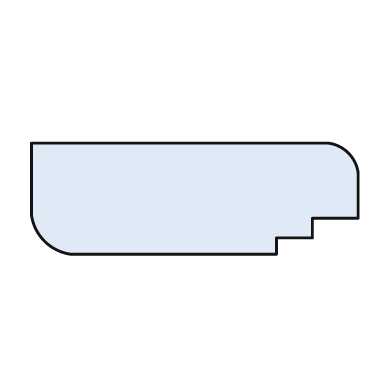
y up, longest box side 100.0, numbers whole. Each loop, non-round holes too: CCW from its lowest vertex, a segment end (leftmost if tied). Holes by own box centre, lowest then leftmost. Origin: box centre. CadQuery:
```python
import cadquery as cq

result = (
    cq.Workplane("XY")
    .moveTo(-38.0, -17.0)
    .lineTo(25.0, -17.0)
    .lineTo(25.0, -12.0)
    .lineTo(36.0, -12.0)
    .lineTo(36.0, -6.0)
    .lineTo(50.0, -6.0)
    .lineTo(50.0, 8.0)
    .threePointArc((47.0, 14.0), (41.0, 17.0))
    .lineTo(-50.0, 17.0)
    .lineTo(-50.0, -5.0)
    .threePointArc((-46.0, -13.0), (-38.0, -17.0))
    .close()
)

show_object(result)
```